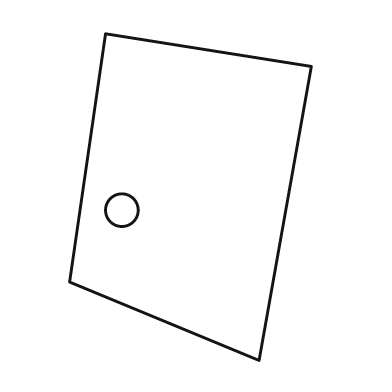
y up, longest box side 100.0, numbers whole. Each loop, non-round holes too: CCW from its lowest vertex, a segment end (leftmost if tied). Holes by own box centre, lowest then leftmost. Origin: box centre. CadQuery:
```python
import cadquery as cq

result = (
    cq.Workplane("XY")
    .moveTo(21.0, -50.0)
    .lineTo(37.0, 40.0)
    .lineTo(-26.0, 50.0)
    .lineTo(-37.0, -26.0)
    .close()
    .moveTo(-21.0, -4.0)
    .circle(5.0)
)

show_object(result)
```